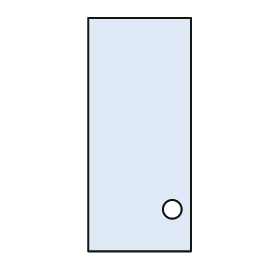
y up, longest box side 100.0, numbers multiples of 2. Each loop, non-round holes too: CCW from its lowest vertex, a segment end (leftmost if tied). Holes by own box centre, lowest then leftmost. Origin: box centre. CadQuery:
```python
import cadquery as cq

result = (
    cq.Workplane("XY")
    .moveTo(-22.0, -50.0)
    .lineTo(22.0, -50.0)
    .lineTo(22.0, 50.0)
    .lineTo(-22.0, 50.0)
    .close()
    .moveTo(14.0, -32.0)
    .circle(4.0)
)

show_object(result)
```